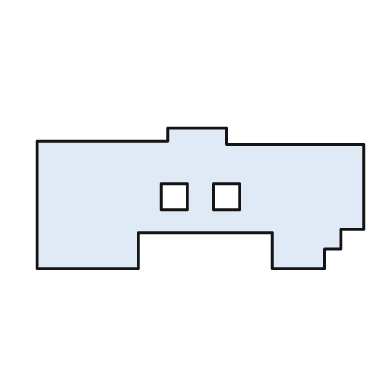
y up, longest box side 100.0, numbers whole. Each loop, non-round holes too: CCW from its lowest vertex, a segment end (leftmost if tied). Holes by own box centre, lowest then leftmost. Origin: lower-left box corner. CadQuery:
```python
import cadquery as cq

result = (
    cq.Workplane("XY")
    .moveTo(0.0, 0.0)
    .lineTo(31.0, 0.0)
    .lineTo(31.0, 11.0)
    .lineTo(72.0, 11.0)
    .lineTo(72.0, 0.0)
    .lineTo(88.0, 0.0)
    .lineTo(88.0, 6.0)
    .lineTo(93.0, 6.0)
    .lineTo(93.0, 12.0)
    .lineTo(100.0, 12.0)
    .lineTo(100.0, 38.0)
    .lineTo(58.0, 38.0)
    .lineTo(58.0, 43.0)
    .lineTo(40.0, 43.0)
    .lineTo(40.0, 39.0)
    .lineTo(0.0, 39.0)
    .close()
    .moveTo(38.0, 18.0)
    .lineTo(46.0, 18.0)
    .lineTo(46.0, 26.0)
    .lineTo(38.0, 26.0)
    .close()
    .moveTo(54.0, 18.0)
    .lineTo(62.0, 18.0)
    .lineTo(62.0, 26.0)
    .lineTo(54.0, 26.0)
    .close()
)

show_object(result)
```